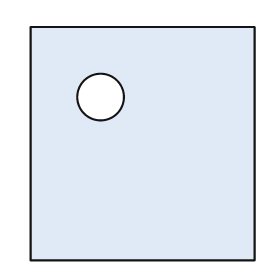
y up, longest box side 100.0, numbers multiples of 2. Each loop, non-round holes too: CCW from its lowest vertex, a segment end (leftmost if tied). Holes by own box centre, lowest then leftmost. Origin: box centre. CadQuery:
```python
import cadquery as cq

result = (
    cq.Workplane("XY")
    .moveTo(-48.0, -50.0)
    .lineTo(48.0, -50.0)
    .lineTo(48.0, 50.0)
    .lineTo(-48.0, 50.0)
    .close()
    .moveTo(-18.0, 20.0)
    .circle(10.0)
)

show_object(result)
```